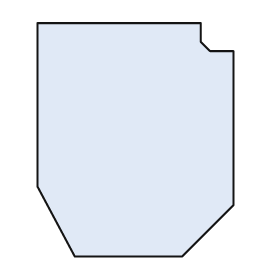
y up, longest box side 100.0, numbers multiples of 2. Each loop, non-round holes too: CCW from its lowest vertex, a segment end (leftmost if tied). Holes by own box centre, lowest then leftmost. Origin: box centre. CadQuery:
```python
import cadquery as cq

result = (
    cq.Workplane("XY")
    .moveTo(-26.0, -50.0)
    .lineTo(20.0, -50.0)
    .lineTo(42.0, -28.0)
    .lineTo(42.0, 38.0)
    .lineTo(32.0, 38.0)
    .lineTo(28.0, 42.0)
    .lineTo(28.0, 50.0)
    .lineTo(-42.0, 50.0)
    .lineTo(-42.0, -20.0)
    .close()
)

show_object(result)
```